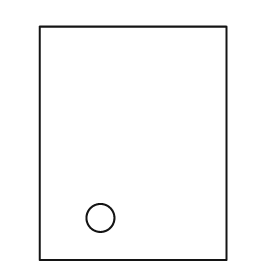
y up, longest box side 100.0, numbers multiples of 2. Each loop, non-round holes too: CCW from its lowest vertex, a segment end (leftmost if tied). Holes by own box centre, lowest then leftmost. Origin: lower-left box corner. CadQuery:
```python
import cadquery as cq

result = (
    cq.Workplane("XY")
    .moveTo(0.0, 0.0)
    .lineTo(80.0, 0.0)
    .lineTo(80.0, 100.0)
    .lineTo(0.0, 100.0)
    .close()
    .moveTo(26.0, 18.0)
    .circle(6.0)
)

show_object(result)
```